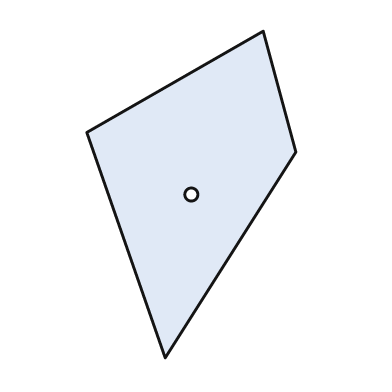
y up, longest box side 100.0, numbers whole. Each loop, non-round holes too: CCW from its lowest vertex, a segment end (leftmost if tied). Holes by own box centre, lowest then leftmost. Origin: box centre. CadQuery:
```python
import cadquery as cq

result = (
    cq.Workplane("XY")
    .moveTo(-8.0, -50.0)
    .lineTo(32.0, 13.0)
    .lineTo(22.0, 50.0)
    .lineTo(-32.0, 19.0)
    .close()
    .moveTo(0.0, 0.0)
    .circle(2.0)
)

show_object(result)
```